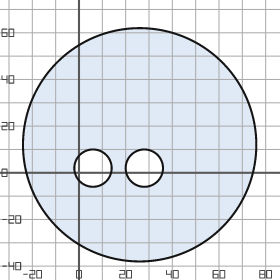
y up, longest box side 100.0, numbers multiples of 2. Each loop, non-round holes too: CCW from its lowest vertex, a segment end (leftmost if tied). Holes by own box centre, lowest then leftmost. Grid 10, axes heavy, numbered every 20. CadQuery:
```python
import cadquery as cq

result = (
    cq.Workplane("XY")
    .moveTo(26.0, 12.0)
    .circle(50.0)
    .moveTo(6.0, 2.0)
    .circle(8.0)
    .moveTo(28.0, 2.0)
    .circle(8.0)
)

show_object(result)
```